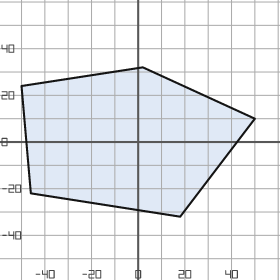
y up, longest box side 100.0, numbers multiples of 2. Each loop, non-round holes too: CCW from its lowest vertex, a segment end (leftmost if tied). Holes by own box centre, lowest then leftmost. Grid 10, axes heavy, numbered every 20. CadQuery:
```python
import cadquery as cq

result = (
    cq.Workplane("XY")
    .moveTo(18.0, -32.0)
    .lineTo(50.0, 10.0)
    .lineTo(2.0, 32.0)
    .lineTo(-50.0, 24.0)
    .lineTo(-46.0, -22.0)
    .close()
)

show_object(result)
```